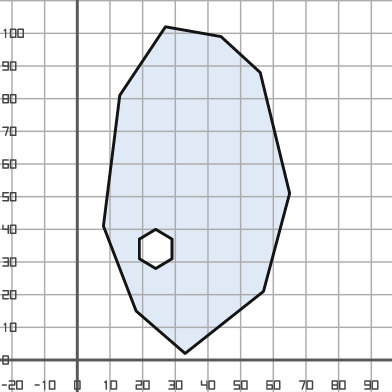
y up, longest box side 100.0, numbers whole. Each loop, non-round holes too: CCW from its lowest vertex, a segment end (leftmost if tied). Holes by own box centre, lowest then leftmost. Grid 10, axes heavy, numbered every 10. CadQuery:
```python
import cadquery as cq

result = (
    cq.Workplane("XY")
    .moveTo(33.0, 2.0)
    .lineTo(57.0, 21.0)
    .lineTo(65.0, 51.0)
    .lineTo(56.0, 88.0)
    .lineTo(44.0, 99.0)
    .lineTo(27.0, 102.0)
    .lineTo(13.0, 81.0)
    .lineTo(8.0, 41.0)
    .lineTo(18.0, 15.0)
    .close()
    .moveTo(24.0, 28.0)
    .lineTo(29.0, 31.0)
    .lineTo(29.0, 37.0)
    .lineTo(24.0, 40.0)
    .lineTo(19.0, 37.0)
    .lineTo(19.0, 31.0)
    .close()
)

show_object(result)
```